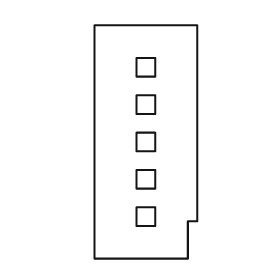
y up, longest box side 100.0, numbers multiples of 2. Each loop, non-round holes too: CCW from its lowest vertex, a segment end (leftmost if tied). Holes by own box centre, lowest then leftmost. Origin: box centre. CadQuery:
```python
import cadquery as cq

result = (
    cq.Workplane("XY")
    .moveTo(-22.0, -50.0)
    .lineTo(18.0, -50.0)
    .lineTo(18.0, -34.0)
    .lineTo(22.0, -34.0)
    .lineTo(22.0, 50.0)
    .lineTo(-22.0, 50.0)
    .close()
    .moveTo(-4.0, -36.0)
    .lineTo(4.0, -36.0)
    .lineTo(4.0, -28.0)
    .lineTo(-4.0, -28.0)
    .close()
    .moveTo(-4.0, -20.0)
    .lineTo(4.0, -20.0)
    .lineTo(4.0, -12.0)
    .lineTo(-4.0, -12.0)
    .close()
    .moveTo(-4.0, -4.0)
    .lineTo(4.0, -4.0)
    .lineTo(4.0, 4.0)
    .lineTo(-4.0, 4.0)
    .close()
    .moveTo(-4.0, 12.0)
    .lineTo(4.0, 12.0)
    .lineTo(4.0, 20.0)
    .lineTo(-4.0, 20.0)
    .close()
    .moveTo(-4.0, 28.0)
    .lineTo(4.0, 28.0)
    .lineTo(4.0, 36.0)
    .lineTo(-4.0, 36.0)
    .close()
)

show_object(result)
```